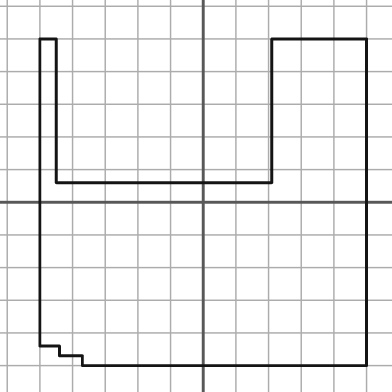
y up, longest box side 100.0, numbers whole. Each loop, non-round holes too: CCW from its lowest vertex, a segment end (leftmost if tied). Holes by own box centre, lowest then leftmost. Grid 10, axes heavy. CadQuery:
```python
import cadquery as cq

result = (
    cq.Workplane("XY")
    .moveTo(-37.0, -50.0)
    .lineTo(50.0, -50.0)
    .lineTo(50.0, 50.0)
    .lineTo(21.0, 50.0)
    .lineTo(21.0, 6.0)
    .lineTo(-45.0, 6.0)
    .lineTo(-45.0, 50.0)
    .lineTo(-50.0, 50.0)
    .lineTo(-50.0, -44.0)
    .lineTo(-44.0, -44.0)
    .lineTo(-44.0, -47.0)
    .lineTo(-37.0, -47.0)
    .close()
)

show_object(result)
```